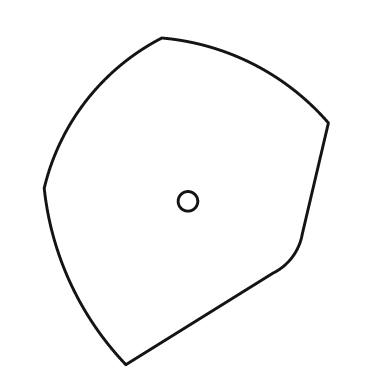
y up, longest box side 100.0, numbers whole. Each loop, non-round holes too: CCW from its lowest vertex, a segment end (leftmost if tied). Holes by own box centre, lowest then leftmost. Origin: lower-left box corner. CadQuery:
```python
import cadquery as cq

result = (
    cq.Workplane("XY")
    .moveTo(25.0, 0.0)
    .lineTo(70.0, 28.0)
    .threePointArc((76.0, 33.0), (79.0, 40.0))
    .lineTo(87.0, 74.0)
    .threePointArc((64.0, 92.0), (36.0, 100.0))
    .threePointArc((13.0, 81.0), (0.0, 54.0))
    .threePointArc((8.0, 25.0), (25.0, 0.0))
    .close()
    .moveTo(44.0, 50.0)
    .circle(3.0)
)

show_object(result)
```